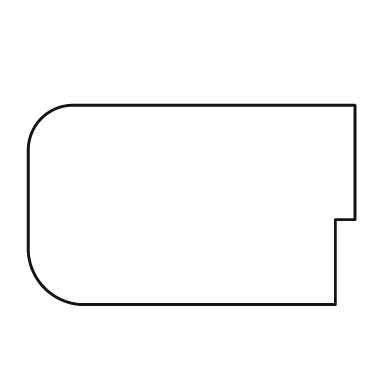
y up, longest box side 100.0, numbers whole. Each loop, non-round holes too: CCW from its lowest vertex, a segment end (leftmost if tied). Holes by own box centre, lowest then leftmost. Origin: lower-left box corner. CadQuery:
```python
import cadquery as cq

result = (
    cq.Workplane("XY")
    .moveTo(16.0, 0.0)
    .lineTo(94.0, 0.0)
    .lineTo(94.0, 26.0)
    .lineTo(100.0, 26.0)
    .lineTo(100.0, 61.0)
    .lineTo(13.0, 61.0)
    .threePointArc((4.0, 57.0), (0.0, 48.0))
    .lineTo(0.0, 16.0)
    .threePointArc((5.0, 5.0), (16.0, 0.0))
    .close()
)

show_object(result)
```